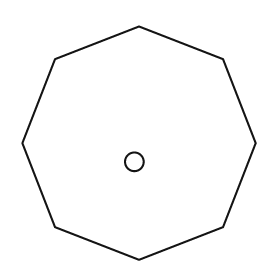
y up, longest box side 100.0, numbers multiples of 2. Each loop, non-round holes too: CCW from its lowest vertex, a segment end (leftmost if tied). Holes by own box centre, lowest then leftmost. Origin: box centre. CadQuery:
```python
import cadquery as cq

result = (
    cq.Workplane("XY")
    .moveTo(0.0, -50.0)
    .lineTo(36.0, -36.0)
    .lineTo(50.0, 0.0)
    .lineTo(36.0, 36.0)
    .lineTo(0.0, 50.0)
    .lineTo(-36.0, 36.0)
    .lineTo(-50.0, 0.0)
    .lineTo(-36.0, -36.0)
    .close()
    .moveTo(-2.0, -8.0)
    .circle(4.0)
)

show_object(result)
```